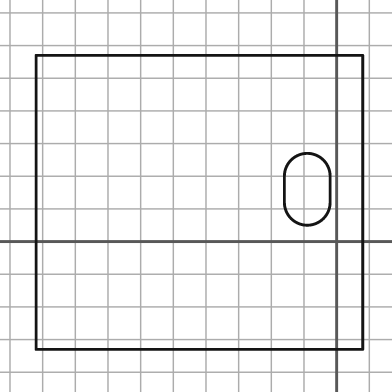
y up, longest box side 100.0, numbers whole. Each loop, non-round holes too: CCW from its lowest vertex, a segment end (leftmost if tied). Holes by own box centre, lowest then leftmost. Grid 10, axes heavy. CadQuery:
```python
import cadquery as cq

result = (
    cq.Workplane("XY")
    .moveTo(-92.0, -33.0)
    .lineTo(8.0, -33.0)
    .lineTo(8.0, 57.0)
    .lineTo(-92.0, 57.0)
    .close()
    .moveTo(-16.0, 12.0)
    .threePointArc((-9.0, 5.0), (-2.0, 12.0))
    .lineTo(-2.0, 20.0)
    .threePointArc((-9.0, 27.0), (-16.0, 20.0))
    .close()
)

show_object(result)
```